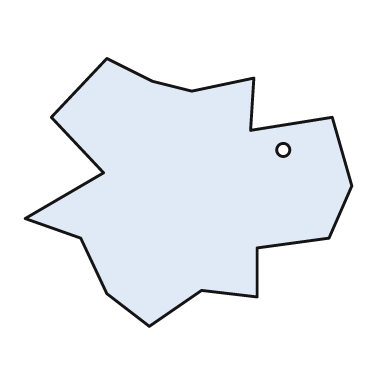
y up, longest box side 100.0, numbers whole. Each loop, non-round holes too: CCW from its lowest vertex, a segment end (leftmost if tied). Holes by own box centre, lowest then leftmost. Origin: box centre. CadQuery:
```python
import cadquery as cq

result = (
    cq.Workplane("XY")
    .moveTo(-12.0, -41.0)
    .lineTo(4.0, -30.0)
    .lineTo(21.0, -32.0)
    .lineTo(21.0, -17.0)
    .lineTo(43.0, -14.0)
    .lineTo(50.0, 2.0)
    .lineTo(44.0, 23.0)
    .lineTo(19.0, 19.0)
    .lineTo(20.0, 35.0)
    .lineTo(1.0, 31.0)
    .lineTo(-11.0, 34.0)
    .lineTo(-25.0, 41.0)
    .lineTo(-42.0, 23.0)
    .lineTo(-26.0, 6.0)
    .lineTo(-50.0, -8.0)
    .lineTo(-33.0, -14.0)
    .lineTo(-25.0, -31.0)
    .close()
    .moveTo(29.0, 13.0)
    .circle(2.0)
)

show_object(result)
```